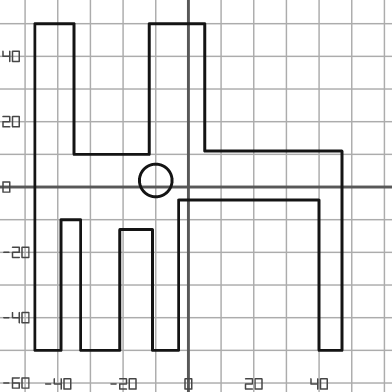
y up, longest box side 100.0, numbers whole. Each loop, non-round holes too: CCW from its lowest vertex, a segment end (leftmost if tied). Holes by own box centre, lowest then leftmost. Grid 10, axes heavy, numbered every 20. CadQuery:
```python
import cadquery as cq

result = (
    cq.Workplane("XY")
    .moveTo(-47.0, -50.0)
    .lineTo(-39.0, -50.0)
    .lineTo(-39.0, -10.0)
    .lineTo(-33.0, -10.0)
    .lineTo(-33.0, -50.0)
    .lineTo(-21.0, -50.0)
    .lineTo(-21.0, -13.0)
    .lineTo(-11.0, -13.0)
    .lineTo(-11.0, -50.0)
    .lineTo(-3.0, -50.0)
    .lineTo(-3.0, -4.0)
    .lineTo(40.0, -4.0)
    .lineTo(40.0, -50.0)
    .lineTo(47.0, -50.0)
    .lineTo(47.0, 11.0)
    .lineTo(5.0, 11.0)
    .lineTo(5.0, 50.0)
    .lineTo(-12.0, 50.0)
    .lineTo(-12.0, 10.0)
    .lineTo(-35.0, 10.0)
    .lineTo(-35.0, 50.0)
    .lineTo(-47.0, 50.0)
    .close()
    .moveTo(-10.0, 2.0)
    .circle(5.0)
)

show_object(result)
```